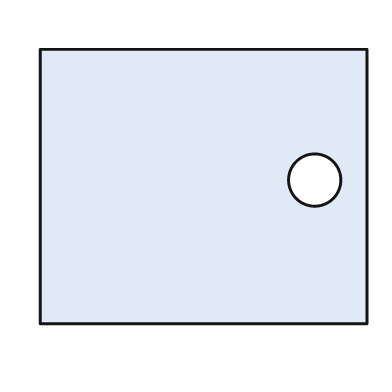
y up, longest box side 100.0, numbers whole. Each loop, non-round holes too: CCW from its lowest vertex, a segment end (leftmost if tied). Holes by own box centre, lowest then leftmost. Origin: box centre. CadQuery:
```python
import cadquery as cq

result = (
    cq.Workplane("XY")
    .moveTo(-50.0, -42.0)
    .lineTo(50.0, -42.0)
    .lineTo(50.0, 42.0)
    .lineTo(-50.0, 42.0)
    .close()
    .moveTo(34.0, 2.0)
    .circle(8.0)
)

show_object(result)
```